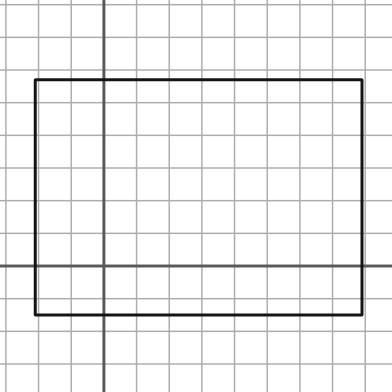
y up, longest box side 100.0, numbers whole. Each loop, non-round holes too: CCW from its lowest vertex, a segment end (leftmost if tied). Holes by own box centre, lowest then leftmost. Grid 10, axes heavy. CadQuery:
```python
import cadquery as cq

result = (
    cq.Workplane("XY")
    .moveTo(-21.0, -15.0)
    .lineTo(79.0, -15.0)
    .lineTo(79.0, 57.0)
    .lineTo(-21.0, 57.0)
    .close()
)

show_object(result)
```